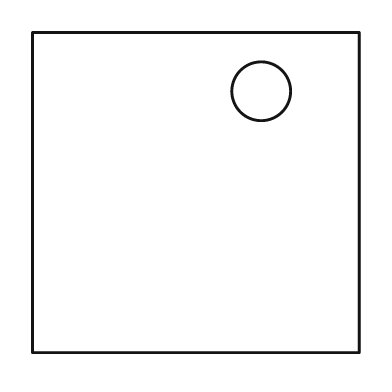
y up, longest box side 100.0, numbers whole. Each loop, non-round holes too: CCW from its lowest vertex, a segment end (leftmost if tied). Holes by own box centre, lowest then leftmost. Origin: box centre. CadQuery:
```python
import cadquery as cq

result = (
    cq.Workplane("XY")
    .moveTo(-50.0, -49.0)
    .lineTo(50.0, -49.0)
    .lineTo(50.0, 49.0)
    .lineTo(-50.0, 49.0)
    .close()
    .moveTo(20.0, 31.0)
    .circle(9.0)
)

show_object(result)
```